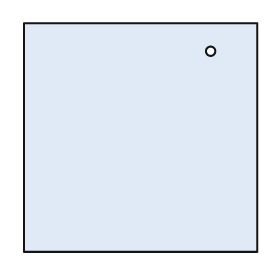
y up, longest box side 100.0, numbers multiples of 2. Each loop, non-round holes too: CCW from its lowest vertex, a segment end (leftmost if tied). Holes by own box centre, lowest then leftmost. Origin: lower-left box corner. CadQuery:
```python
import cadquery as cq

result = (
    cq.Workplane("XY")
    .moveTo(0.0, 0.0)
    .lineTo(100.0, 0.0)
    .lineTo(100.0, 98.0)
    .lineTo(0.0, 98.0)
    .close()
    .moveTo(80.0, 86.0)
    .circle(2.0)
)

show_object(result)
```